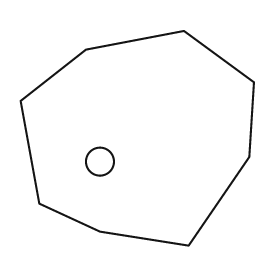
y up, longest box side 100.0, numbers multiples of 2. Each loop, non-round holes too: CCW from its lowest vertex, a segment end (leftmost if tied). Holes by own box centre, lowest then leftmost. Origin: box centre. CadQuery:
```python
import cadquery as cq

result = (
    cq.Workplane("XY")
    .moveTo(22.0, -46.0)
    .lineTo(48.0, -8.0)
    .lineTo(50.0, 24.0)
    .lineTo(20.0, 46.0)
    .lineTo(-22.0, 38.0)
    .lineTo(-50.0, 16.0)
    .lineTo(-42.0, -28.0)
    .lineTo(-16.0, -40.0)
    .close()
    .moveTo(-16.0, -10.0)
    .circle(6.0)
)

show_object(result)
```